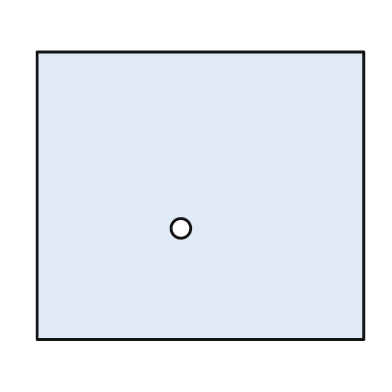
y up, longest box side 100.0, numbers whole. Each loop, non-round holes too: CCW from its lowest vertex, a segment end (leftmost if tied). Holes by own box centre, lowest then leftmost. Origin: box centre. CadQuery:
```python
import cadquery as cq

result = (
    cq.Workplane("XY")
    .moveTo(-50.0, -44.0)
    .lineTo(50.0, -44.0)
    .lineTo(50.0, 44.0)
    .lineTo(-50.0, 44.0)
    .close()
    .moveTo(-6.0, -10.0)
    .circle(3.0)
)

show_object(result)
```